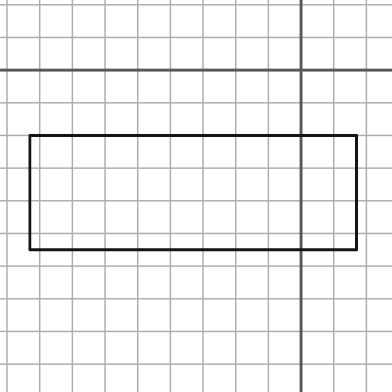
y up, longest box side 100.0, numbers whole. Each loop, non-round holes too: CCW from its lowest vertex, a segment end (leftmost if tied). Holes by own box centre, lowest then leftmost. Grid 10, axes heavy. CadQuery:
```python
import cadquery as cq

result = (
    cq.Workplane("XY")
    .moveTo(-83.0, -55.0)
    .lineTo(17.0, -55.0)
    .lineTo(17.0, -20.0)
    .lineTo(-83.0, -20.0)
    .close()
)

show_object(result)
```